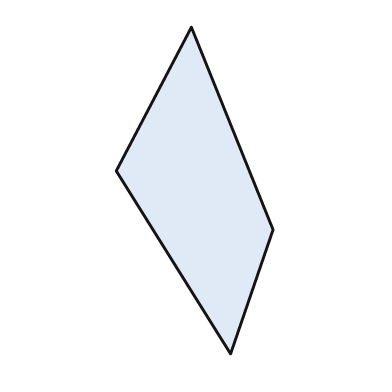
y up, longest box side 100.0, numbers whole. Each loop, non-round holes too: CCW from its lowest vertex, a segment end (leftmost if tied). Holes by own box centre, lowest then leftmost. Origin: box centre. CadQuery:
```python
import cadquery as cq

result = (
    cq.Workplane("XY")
    .moveTo(11.0, -50.0)
    .lineTo(24.0, -12.0)
    .lineTo(-1.0, 50.0)
    .lineTo(-24.0, 6.0)
    .close()
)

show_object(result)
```